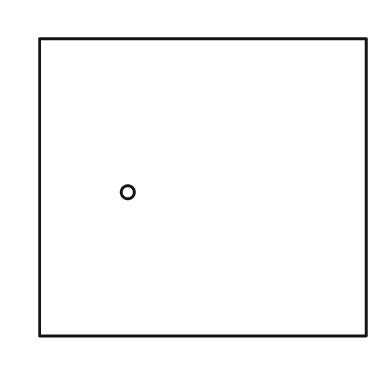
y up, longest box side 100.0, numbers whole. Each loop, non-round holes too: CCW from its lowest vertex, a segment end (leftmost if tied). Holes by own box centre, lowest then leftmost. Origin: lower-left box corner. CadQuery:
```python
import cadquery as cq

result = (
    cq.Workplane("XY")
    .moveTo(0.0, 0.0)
    .lineTo(100.0, 0.0)
    .lineTo(100.0, 91.0)
    .lineTo(0.0, 91.0)
    .close()
    .moveTo(27.0, 44.0)
    .circle(2.0)
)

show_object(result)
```